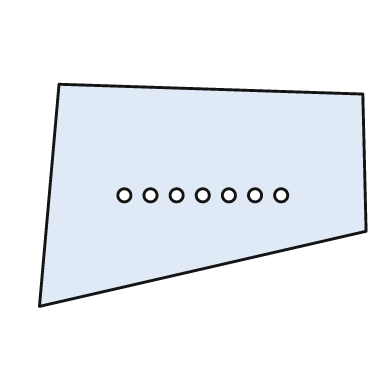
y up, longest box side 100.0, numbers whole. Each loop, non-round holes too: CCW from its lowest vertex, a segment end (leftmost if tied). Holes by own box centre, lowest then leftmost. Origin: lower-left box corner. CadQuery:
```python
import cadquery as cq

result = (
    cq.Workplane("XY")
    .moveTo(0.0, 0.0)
    .lineTo(100.0, 23.0)
    .lineTo(99.0, 65.0)
    .lineTo(6.0, 68.0)
    .close()
    .moveTo(26.0, 34.0)
    .circle(2.0)
    .moveTo(34.0, 34.0)
    .circle(2.0)
    .moveTo(42.0, 34.0)
    .circle(2.0)
    .moveTo(50.0, 34.0)
    .circle(2.0)
    .moveTo(58.0, 34.0)
    .circle(2.0)
    .moveTo(66.0, 34.0)
    .circle(2.0)
    .moveTo(74.0, 34.0)
    .circle(2.0)
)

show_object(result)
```